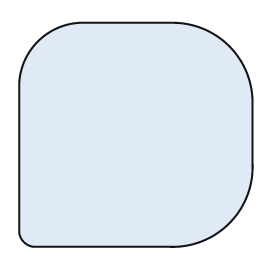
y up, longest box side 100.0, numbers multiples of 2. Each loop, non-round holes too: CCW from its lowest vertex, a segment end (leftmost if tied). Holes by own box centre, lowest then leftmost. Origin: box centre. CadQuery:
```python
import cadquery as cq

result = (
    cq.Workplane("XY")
    .moveTo(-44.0, -48.0)
    .lineTo(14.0, -48.0)
    .threePointArc((40.0, -38.0), (50.0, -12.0))
    .lineTo(50.0, 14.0)
    .threePointArc((40.0, 38.0), (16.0, 48.0))
    .lineTo(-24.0, 48.0)
    .threePointArc((-42.0, 40.0), (-50.0, 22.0))
    .lineTo(-50.0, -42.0)
    .threePointArc((-48.0, -46.0), (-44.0, -48.0))
    .close()
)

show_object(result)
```